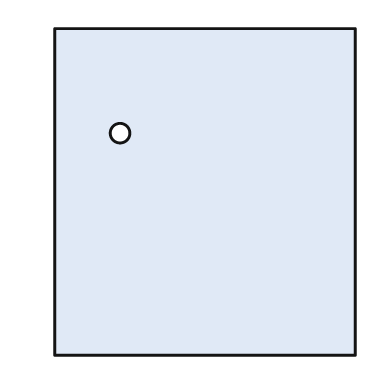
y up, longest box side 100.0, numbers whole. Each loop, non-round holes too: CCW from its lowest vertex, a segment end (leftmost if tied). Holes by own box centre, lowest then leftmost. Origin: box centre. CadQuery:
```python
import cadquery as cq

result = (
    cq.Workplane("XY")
    .moveTo(-46.0, -50.0)
    .lineTo(46.0, -50.0)
    .lineTo(46.0, 50.0)
    .lineTo(-46.0, 50.0)
    .close()
    .moveTo(-26.0, 18.0)
    .circle(3.0)
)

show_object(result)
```